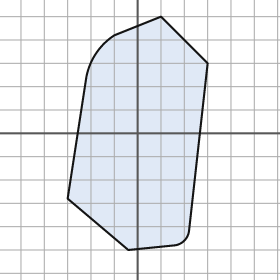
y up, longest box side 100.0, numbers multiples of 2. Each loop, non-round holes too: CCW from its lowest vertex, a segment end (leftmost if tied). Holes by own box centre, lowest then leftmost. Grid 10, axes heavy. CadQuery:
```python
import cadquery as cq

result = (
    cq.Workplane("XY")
    .moveTo(-4.0, -50.0)
    .lineTo(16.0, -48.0)
    .threePointArc((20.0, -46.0), (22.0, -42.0))
    .lineTo(30.0, 30.0)
    .lineTo(10.0, 50.0)
    .lineTo(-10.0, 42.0)
    .threePointArc((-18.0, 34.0), (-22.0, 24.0))
    .lineTo(-30.0, -28.0)
    .close()
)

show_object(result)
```